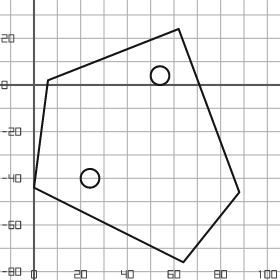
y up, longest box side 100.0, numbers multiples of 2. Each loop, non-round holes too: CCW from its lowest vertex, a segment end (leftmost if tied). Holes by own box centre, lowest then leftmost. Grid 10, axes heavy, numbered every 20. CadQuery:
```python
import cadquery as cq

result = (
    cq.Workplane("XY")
    .moveTo(64.0, -76.0)
    .lineTo(88.0, -46.0)
    .lineTo(62.0, 24.0)
    .lineTo(6.0, 2.0)
    .lineTo(0.0, -44.0)
    .close()
    .moveTo(24.0, -40.0)
    .circle(4.0)
    .moveTo(54.0, 4.0)
    .circle(4.0)
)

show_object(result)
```